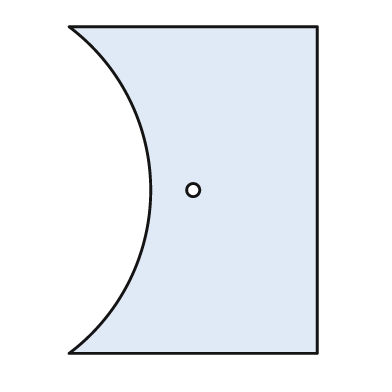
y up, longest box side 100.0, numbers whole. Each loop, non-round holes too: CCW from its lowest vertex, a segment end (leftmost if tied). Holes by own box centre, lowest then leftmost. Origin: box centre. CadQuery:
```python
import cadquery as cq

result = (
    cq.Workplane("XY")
    .moveTo(-38.0, -50.0)
    .lineTo(38.0, -50.0)
    .lineTo(38.0, 50.0)
    .lineTo(-38.0, 50.0)
    .threePointArc((-13.0, 0.0), (-38.0, -50.0))
    .close()
    .moveTo(0.0, 0.0)
    .circle(2.0)
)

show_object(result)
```